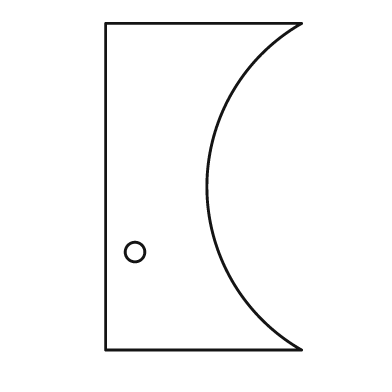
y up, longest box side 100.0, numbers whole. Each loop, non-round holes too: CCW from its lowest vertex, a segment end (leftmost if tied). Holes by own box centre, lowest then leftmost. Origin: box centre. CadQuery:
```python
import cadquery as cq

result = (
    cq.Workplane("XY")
    .moveTo(-30.0, -50.0)
    .lineTo(30.0, -50.0)
    .threePointArc((1.0, 0.0), (30.0, 50.0))
    .lineTo(-30.0, 50.0)
    .close()
    .moveTo(-21.0, -20.0)
    .circle(3.0)
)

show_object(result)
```